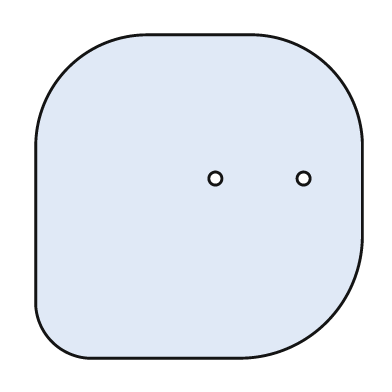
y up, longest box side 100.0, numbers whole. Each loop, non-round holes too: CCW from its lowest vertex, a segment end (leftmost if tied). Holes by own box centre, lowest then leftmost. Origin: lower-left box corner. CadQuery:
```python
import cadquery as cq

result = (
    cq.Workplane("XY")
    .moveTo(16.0, 0.0)
    .lineTo(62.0, 0.0)
    .threePointArc((89.0, 11.0), (100.0, 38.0))
    .lineTo(100.0, 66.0)
    .threePointArc((90.0, 89.0), (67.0, 99.0))
    .lineTo(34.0, 99.0)
    .threePointArc((10.0, 89.0), (0.0, 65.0))
    .lineTo(0.0, 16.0)
    .threePointArc((5.0, 5.0), (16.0, 0.0))
    .close()
    .moveTo(55.0, 55.0)
    .circle(2.0)
    .moveTo(82.0, 55.0)
    .circle(2.0)
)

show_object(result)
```